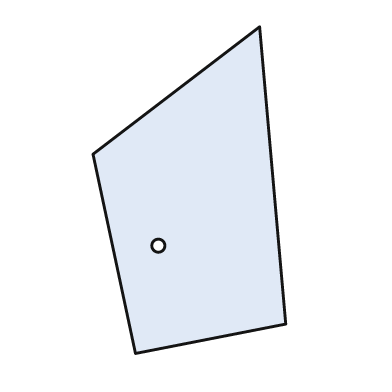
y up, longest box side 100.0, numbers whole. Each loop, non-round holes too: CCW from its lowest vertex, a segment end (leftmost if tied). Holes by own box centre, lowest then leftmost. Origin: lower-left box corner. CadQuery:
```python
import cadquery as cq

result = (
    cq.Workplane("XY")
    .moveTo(13.0, 0.0)
    .lineTo(59.0, 9.0)
    .lineTo(51.0, 100.0)
    .lineTo(0.0, 61.0)
    .close()
    .moveTo(20.0, 33.0)
    .circle(2.0)
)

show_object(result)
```